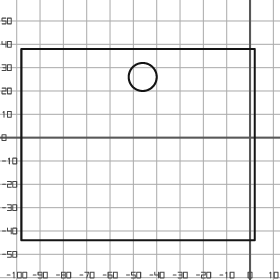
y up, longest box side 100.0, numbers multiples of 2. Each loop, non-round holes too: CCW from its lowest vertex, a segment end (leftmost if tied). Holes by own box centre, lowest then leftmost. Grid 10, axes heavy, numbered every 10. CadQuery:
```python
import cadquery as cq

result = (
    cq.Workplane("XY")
    .moveTo(-98.0, -44.0)
    .lineTo(2.0, -44.0)
    .lineTo(2.0, 38.0)
    .lineTo(-98.0, 38.0)
    .close()
    .moveTo(-46.0, 26.0)
    .circle(6.0)
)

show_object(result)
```